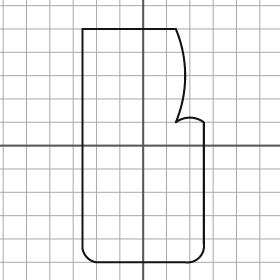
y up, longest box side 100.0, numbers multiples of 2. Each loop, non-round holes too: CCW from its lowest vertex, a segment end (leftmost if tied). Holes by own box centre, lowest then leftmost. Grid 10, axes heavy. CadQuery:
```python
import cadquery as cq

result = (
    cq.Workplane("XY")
    .moveTo(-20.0, -50.0)
    .lineTo(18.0, -50.0)
    .threePointArc((24.0, -48.0), (26.0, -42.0))
    .lineTo(26.0, 10.0)
    .threePointArc((20.0, 12.0), (14.0, 10.0))
    .threePointArc((18.0, 30.0), (14.0, 50.0))
    .lineTo(-26.0, 50.0)
    .lineTo(-26.0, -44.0)
    .threePointArc((-24.0, -48.0), (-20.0, -50.0))
    .close()
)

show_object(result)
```